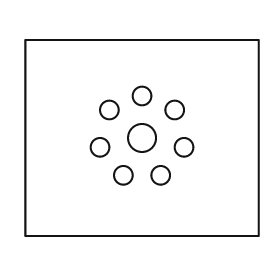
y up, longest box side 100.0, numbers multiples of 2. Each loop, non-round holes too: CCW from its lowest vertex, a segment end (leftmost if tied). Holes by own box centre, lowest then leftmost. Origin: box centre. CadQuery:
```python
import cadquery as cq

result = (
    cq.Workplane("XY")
    .moveTo(-50.0, -42.0)
    .lineTo(50.0, -42.0)
    .lineTo(50.0, 42.0)
    .lineTo(-50.0, 42.0)
    .close()
    .moveTo(-8.0, -16.0)
    .circle(4.0)
    .moveTo(8.0, -16.0)
    .circle(4.0)
    .moveTo(-18.0, -4.0)
    .circle(4.0)
    .moveTo(18.0, -4.0)
    .circle(4.0)
    .moveTo(0.0, 0.0)
    .circle(6.0)
    .moveTo(-14.0, 12.0)
    .circle(4.0)
    .moveTo(14.0, 12.0)
    .circle(4.0)
    .moveTo(0.0, 18.0)
    .circle(4.0)
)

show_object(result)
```